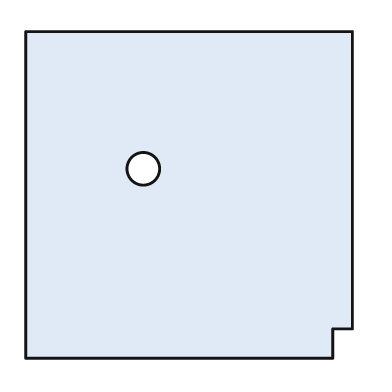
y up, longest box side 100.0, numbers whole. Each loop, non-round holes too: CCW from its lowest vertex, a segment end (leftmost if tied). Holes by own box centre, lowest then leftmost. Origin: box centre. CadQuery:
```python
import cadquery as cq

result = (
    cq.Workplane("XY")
    .moveTo(-50.0, -50.0)
    .lineTo(44.0, -50.0)
    .lineTo(44.0, -41.0)
    .lineTo(50.0, -41.0)
    .lineTo(50.0, 50.0)
    .lineTo(-50.0, 50.0)
    .close()
    .moveTo(-14.0, 8.0)
    .circle(5.0)
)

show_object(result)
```